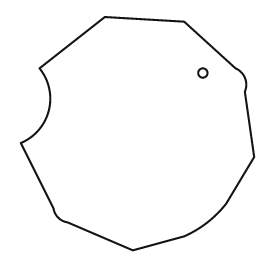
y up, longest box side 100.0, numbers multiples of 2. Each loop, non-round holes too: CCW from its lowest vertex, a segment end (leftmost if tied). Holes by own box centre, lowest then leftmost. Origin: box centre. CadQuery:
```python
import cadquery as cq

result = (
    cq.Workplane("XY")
    .moveTo(-2.0, -50.0)
    .lineTo(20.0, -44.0)
    .threePointArc((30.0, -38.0), (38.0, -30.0))
    .lineTo(50.0, -10.0)
    .lineTo(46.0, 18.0)
    .threePointArc((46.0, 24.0), (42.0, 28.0))
    .lineTo(20.0, 48.0)
    .lineTo(-14.0, 50.0)
    .lineTo(-42.0, 28.0)
    .threePointArc((-38.0, 10.0), (-50.0, -4.0))
    .lineTo(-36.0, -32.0)
    .threePointArc((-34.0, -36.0), (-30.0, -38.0))
    .close()
    .moveTo(28.0, 26.0)
    .circle(2.0)
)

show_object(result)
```